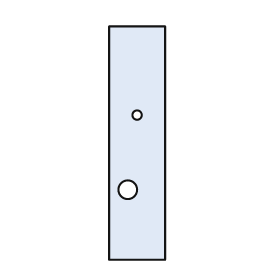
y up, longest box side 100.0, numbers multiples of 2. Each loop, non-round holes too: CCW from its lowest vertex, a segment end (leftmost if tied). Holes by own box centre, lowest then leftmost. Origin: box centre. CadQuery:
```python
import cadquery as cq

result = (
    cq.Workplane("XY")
    .moveTo(-12.0, -50.0)
    .lineTo(12.0, -50.0)
    .lineTo(12.0, 50.0)
    .lineTo(-12.0, 50.0)
    .close()
    .moveTo(-4.0, -20.0)
    .circle(4.0)
    .moveTo(0.0, 12.0)
    .circle(2.0)
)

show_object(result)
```